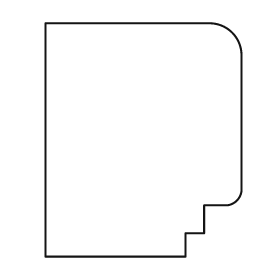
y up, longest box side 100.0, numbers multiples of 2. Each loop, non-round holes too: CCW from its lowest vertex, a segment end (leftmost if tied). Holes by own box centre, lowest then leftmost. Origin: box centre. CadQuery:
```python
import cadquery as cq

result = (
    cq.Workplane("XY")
    .moveTo(-42.0, -50.0)
    .lineTo(18.0, -50.0)
    .lineTo(18.0, -40.0)
    .lineTo(26.0, -40.0)
    .lineTo(26.0, -28.0)
    .lineTo(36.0, -28.0)
    .threePointArc((40.0, -26.0), (42.0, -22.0))
    .lineTo(42.0, 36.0)
    .threePointArc((38.0, 46.0), (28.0, 50.0))
    .lineTo(-42.0, 50.0)
    .close()
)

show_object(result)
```